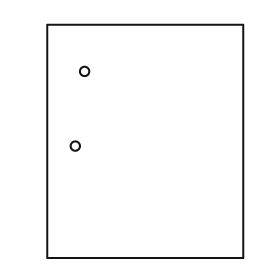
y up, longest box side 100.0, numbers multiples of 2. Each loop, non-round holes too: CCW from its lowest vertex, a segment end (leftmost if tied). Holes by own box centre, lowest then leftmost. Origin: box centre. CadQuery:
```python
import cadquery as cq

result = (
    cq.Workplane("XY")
    .moveTo(-42.0, -50.0)
    .lineTo(42.0, -50.0)
    .lineTo(42.0, 50.0)
    .lineTo(-42.0, 50.0)
    .close()
    .moveTo(-30.0, -2.0)
    .circle(2.0)
    .moveTo(-26.0, 30.0)
    .circle(2.0)
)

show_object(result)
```